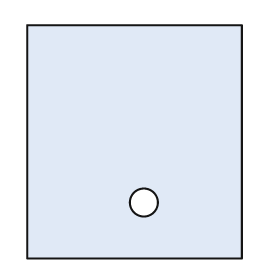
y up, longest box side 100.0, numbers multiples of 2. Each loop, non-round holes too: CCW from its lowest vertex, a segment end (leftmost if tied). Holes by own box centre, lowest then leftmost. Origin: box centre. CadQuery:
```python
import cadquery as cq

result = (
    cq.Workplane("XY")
    .moveTo(-46.0, -50.0)
    .lineTo(46.0, -50.0)
    .lineTo(46.0, 50.0)
    .lineTo(-46.0, 50.0)
    .close()
    .moveTo(4.0, -26.0)
    .circle(6.0)
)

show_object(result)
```